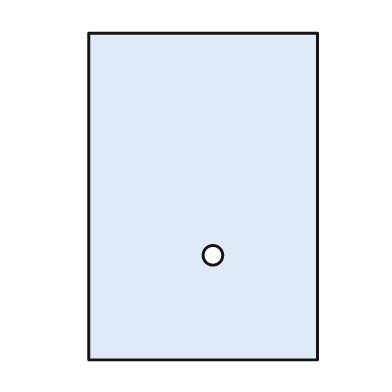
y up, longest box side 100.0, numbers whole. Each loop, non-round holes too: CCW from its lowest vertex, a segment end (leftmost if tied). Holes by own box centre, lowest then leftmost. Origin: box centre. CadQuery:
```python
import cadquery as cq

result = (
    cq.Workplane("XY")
    .moveTo(-35.0, -50.0)
    .lineTo(35.0, -50.0)
    .lineTo(35.0, 50.0)
    .lineTo(-35.0, 50.0)
    .close()
    .moveTo(3.0, -18.0)
    .circle(3.0)
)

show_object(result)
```